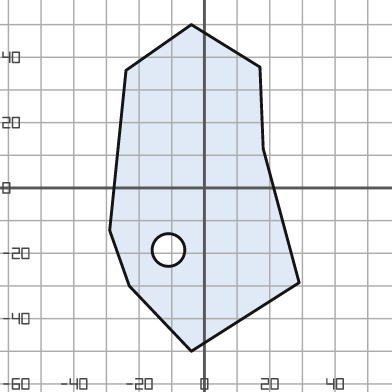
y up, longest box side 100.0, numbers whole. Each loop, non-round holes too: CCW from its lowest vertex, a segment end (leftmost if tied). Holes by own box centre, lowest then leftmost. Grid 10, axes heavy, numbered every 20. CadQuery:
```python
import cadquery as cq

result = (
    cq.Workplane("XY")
    .moveTo(-4.0, -50.0)
    .lineTo(29.0, -29.0)
    .lineTo(18.0, 12.0)
    .lineTo(17.0, 37.0)
    .lineTo(-4.0, 50.0)
    .lineTo(-24.0, 36.0)
    .lineTo(-29.0, -13.0)
    .lineTo(-23.0, -30.0)
    .close()
    .moveTo(-11.0, -19.0)
    .circle(5.0)
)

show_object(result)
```